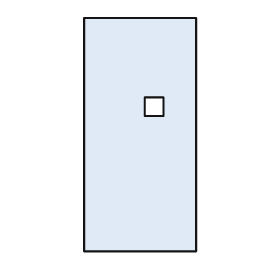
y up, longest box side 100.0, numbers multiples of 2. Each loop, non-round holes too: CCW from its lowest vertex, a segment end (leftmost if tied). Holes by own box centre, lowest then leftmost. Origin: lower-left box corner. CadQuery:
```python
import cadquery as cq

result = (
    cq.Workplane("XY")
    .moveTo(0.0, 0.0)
    .lineTo(48.0, 0.0)
    .lineTo(48.0, 100.0)
    .lineTo(0.0, 100.0)
    .close()
    .moveTo(26.0, 58.0)
    .lineTo(34.0, 58.0)
    .lineTo(34.0, 66.0)
    .lineTo(26.0, 66.0)
    .close()
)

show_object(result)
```